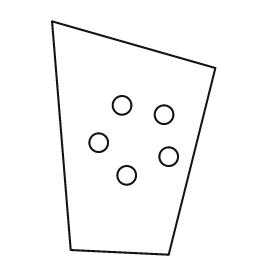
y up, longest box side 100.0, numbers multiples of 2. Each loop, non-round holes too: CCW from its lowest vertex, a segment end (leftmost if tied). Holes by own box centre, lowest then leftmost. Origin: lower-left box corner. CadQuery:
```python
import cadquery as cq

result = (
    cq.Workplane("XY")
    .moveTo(50.0, 0.0)
    .lineTo(70.0, 80.0)
    .lineTo(0.0, 100.0)
    .lineTo(8.0, 2.0)
    .close()
    .moveTo(32.0, 34.0)
    .circle(4.0)
    .moveTo(50.0, 42.0)
    .circle(4.0)
    .moveTo(20.0, 48.0)
    .circle(4.0)
    .moveTo(48.0, 60.0)
    .circle(4.0)
    .moveTo(30.0, 64.0)
    .circle(4.0)
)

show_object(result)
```